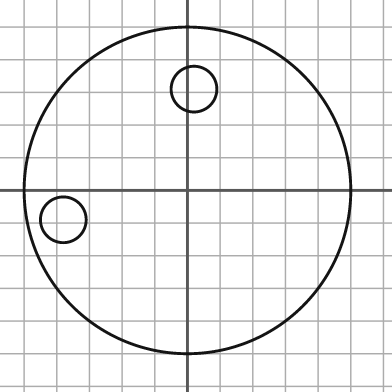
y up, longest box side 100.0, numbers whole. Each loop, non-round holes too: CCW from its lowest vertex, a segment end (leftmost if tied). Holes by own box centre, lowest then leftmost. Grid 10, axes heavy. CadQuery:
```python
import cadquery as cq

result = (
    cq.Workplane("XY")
    .moveTo(0.0, 0.0)
    .circle(50.0)
    .moveTo(-38.0, -9.0)
    .circle(7.0)
    .moveTo(2.0, 31.0)
    .circle(7.0)
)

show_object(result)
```